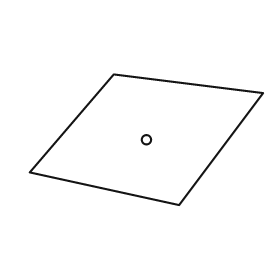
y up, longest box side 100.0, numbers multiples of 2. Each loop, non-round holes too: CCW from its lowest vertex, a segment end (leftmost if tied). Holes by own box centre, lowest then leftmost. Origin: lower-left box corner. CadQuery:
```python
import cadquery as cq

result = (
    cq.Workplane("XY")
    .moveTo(64.0, 0.0)
    .lineTo(100.0, 48.0)
    .lineTo(36.0, 56.0)
    .lineTo(0.0, 14.0)
    .close()
    .moveTo(50.0, 28.0)
    .circle(2.0)
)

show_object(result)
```